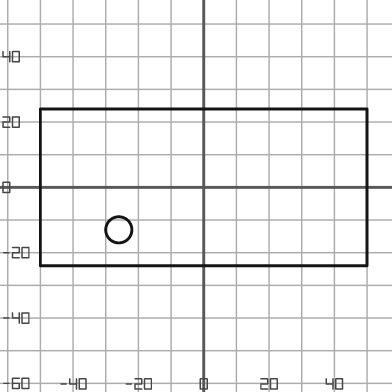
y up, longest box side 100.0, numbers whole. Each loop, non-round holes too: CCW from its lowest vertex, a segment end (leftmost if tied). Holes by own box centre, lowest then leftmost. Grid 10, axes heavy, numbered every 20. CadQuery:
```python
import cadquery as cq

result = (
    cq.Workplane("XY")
    .moveTo(-50.0, -24.0)
    .lineTo(50.0, -24.0)
    .lineTo(50.0, 24.0)
    .lineTo(-50.0, 24.0)
    .close()
    .moveTo(-26.0, -13.0)
    .circle(4.0)
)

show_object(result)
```